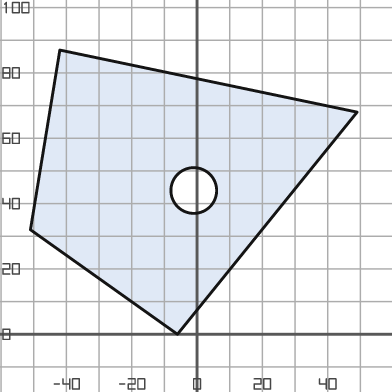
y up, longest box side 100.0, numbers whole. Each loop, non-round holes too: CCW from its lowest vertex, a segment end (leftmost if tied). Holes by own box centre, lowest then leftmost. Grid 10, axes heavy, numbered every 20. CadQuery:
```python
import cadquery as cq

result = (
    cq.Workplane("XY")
    .moveTo(-6.0, 0.0)
    .lineTo(49.0, 68.0)
    .lineTo(-42.0, 87.0)
    .lineTo(-51.0, 32.0)
    .close()
    .moveTo(-1.0, 44.0)
    .circle(7.0)
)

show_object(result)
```